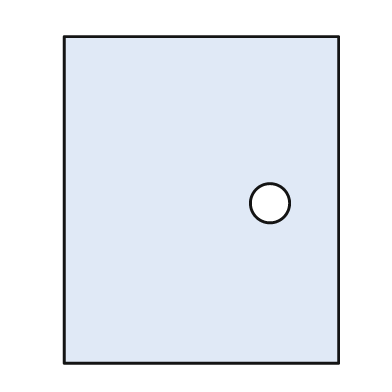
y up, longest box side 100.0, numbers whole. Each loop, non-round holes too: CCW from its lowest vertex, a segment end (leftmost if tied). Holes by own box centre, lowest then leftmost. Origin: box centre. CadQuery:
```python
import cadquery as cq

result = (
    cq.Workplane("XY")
    .moveTo(-42.0, -50.0)
    .lineTo(42.0, -50.0)
    .lineTo(42.0, 50.0)
    .lineTo(-42.0, 50.0)
    .close()
    .moveTo(21.0, -1.0)
    .circle(6.0)
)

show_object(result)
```